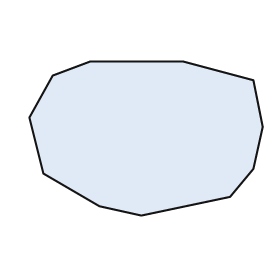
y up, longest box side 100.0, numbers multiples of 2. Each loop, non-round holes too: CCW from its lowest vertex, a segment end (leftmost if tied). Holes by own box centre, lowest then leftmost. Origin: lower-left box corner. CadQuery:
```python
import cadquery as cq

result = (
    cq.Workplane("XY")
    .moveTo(48.0, 0.0)
    .lineTo(86.0, 8.0)
    .lineTo(96.0, 20.0)
    .lineTo(100.0, 38.0)
    .lineTo(96.0, 58.0)
    .lineTo(66.0, 66.0)
    .lineTo(26.0, 66.0)
    .lineTo(10.0, 60.0)
    .lineTo(0.0, 42.0)
    .lineTo(6.0, 18.0)
    .lineTo(30.0, 4.0)
    .close()
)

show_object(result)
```